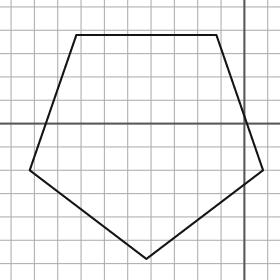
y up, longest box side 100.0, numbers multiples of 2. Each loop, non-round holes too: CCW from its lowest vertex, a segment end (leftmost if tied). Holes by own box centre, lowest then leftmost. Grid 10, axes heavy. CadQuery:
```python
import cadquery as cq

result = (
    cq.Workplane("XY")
    .moveTo(-42.0, -58.0)
    .lineTo(8.0, -20.0)
    .lineTo(-12.0, 38.0)
    .lineTo(-72.0, 38.0)
    .lineTo(-92.0, -20.0)
    .close()
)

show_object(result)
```